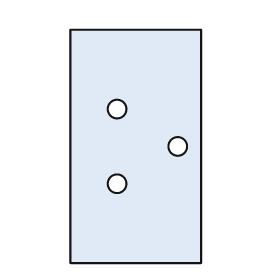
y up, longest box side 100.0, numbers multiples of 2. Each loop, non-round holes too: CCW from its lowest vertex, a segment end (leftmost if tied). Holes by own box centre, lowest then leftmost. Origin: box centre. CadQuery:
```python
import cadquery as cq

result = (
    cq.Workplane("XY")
    .moveTo(-28.0, -50.0)
    .lineTo(28.0, -50.0)
    .lineTo(28.0, 50.0)
    .lineTo(-28.0, 50.0)
    .close()
    .moveTo(-8.0, -16.0)
    .circle(4.0)
    .moveTo(18.0, 0.0)
    .circle(4.0)
    .moveTo(-8.0, 16.0)
    .circle(4.0)
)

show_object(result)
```